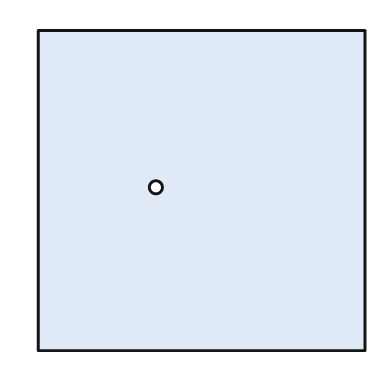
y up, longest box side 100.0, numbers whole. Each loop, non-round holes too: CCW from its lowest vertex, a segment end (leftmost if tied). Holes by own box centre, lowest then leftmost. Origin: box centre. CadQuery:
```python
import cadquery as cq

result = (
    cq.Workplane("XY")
    .moveTo(-50.0, -49.0)
    .lineTo(50.0, -49.0)
    .lineTo(50.0, 49.0)
    .lineTo(-50.0, 49.0)
    .close()
    .moveTo(-14.0, 1.0)
    .circle(2.0)
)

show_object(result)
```